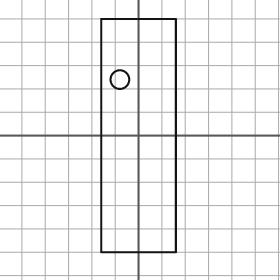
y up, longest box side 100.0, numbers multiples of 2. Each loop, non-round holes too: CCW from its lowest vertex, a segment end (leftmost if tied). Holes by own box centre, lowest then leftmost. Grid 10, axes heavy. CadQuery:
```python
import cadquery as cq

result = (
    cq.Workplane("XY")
    .moveTo(-16.0, -50.0)
    .lineTo(16.0, -50.0)
    .lineTo(16.0, 50.0)
    .lineTo(-16.0, 50.0)
    .close()
    .moveTo(-8.0, 24.0)
    .circle(4.0)
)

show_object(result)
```